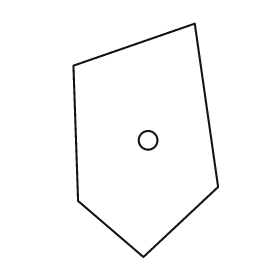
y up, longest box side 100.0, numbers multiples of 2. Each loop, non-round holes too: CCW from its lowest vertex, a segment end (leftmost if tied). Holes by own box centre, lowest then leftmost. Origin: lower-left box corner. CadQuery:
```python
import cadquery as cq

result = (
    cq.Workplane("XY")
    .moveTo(30.0, 0.0)
    .lineTo(62.0, 30.0)
    .lineTo(52.0, 100.0)
    .lineTo(0.0, 82.0)
    .lineTo(2.0, 24.0)
    .close()
    .moveTo(32.0, 50.0)
    .circle(4.0)
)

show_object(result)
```